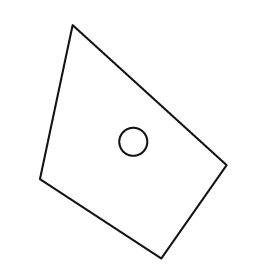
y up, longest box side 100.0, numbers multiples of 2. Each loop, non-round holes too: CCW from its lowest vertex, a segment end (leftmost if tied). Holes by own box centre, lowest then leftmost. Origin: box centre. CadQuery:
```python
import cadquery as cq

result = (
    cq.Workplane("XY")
    .moveTo(12.0, -50.0)
    .lineTo(40.0, -10.0)
    .lineTo(-26.0, 50.0)
    .lineTo(-40.0, -16.0)
    .close()
    .moveTo(0.0, 0.0)
    .circle(6.0)
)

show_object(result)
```